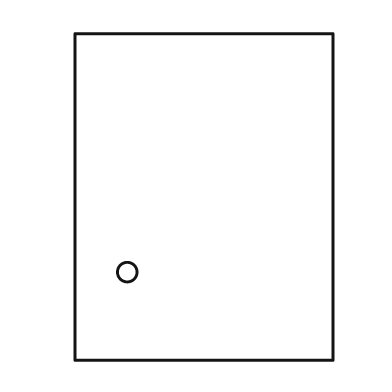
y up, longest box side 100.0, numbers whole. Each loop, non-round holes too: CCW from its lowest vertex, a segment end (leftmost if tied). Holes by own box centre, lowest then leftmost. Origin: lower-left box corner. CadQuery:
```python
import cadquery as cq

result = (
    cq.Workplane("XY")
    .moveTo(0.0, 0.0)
    .lineTo(79.0, 0.0)
    .lineTo(79.0, 100.0)
    .lineTo(0.0, 100.0)
    .close()
    .moveTo(16.0, 27.0)
    .circle(3.0)
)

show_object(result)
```